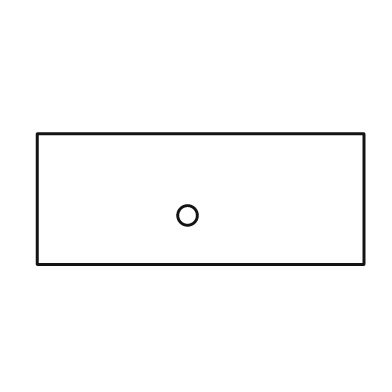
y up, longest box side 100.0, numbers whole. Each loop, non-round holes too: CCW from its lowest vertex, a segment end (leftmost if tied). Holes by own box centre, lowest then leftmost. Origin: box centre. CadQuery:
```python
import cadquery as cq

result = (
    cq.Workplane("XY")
    .moveTo(-50.0, -20.0)
    .lineTo(50.0, -20.0)
    .lineTo(50.0, 20.0)
    .lineTo(-50.0, 20.0)
    .close()
    .moveTo(-4.0, -5.0)
    .circle(3.0)
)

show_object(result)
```